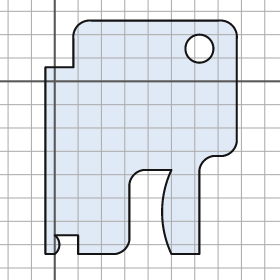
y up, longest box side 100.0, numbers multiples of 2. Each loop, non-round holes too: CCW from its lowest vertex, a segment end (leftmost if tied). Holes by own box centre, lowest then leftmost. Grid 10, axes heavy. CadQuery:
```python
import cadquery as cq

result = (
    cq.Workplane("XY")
    .moveTo(-4.0, -74.0)
    .lineTo(0.0, -74.0)
    .threePointArc((2.0, -70.0), (0.0, -66.0))
    .lineTo(10.0, -66.0)
    .lineTo(10.0, -74.0)
    .lineTo(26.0, -74.0)
    .threePointArc((30.0, -72.0), (32.0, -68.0))
    .lineTo(32.0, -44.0)
    .threePointArc((34.0, -40.0), (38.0, -38.0))
    .lineTo(50.0, -38.0)
    .threePointArc((46.0, -56.0), (50.0, -74.0))
    .lineTo(62.0, -74.0)
    .lineTo(62.0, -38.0)
    .threePointArc((64.0, -34.0), (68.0, -32.0))
    .lineTo(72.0, -32.0)
    .threePointArc((76.0, -30.0), (78.0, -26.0))
    .lineTo(78.0, 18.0)
    .threePointArc((76.0, 24.0), (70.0, 26.0))
    .lineTo(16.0, 26.0)
    .threePointArc((10.0, 24.0), (8.0, 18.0))
    .lineTo(8.0, 6.0)
    .lineTo(-4.0, 6.0)
    .close()
    .moveTo(62.0, 14.0)
    .circle(6.0)
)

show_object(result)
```